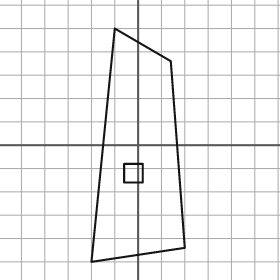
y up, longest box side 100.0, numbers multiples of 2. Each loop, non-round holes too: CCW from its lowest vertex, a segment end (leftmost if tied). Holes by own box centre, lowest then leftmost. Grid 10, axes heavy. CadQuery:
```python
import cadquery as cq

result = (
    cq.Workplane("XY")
    .moveTo(-20.0, -50.0)
    .lineTo(20.0, -44.0)
    .lineTo(14.0, 36.0)
    .lineTo(-10.0, 50.0)
    .close()
    .moveTo(-6.0, -16.0)
    .lineTo(2.0, -16.0)
    .lineTo(2.0, -8.0)
    .lineTo(-6.0, -8.0)
    .close()
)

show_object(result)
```